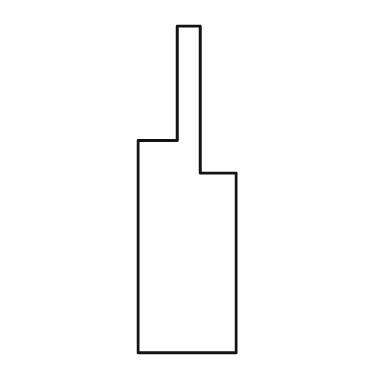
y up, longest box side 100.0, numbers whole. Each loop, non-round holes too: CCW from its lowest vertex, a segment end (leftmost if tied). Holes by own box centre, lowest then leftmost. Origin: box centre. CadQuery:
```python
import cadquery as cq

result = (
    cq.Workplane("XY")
    .moveTo(-15.0, -50.0)
    .lineTo(15.0, -50.0)
    .lineTo(15.0, 5.0)
    .lineTo(4.0, 5.0)
    .lineTo(4.0, 50.0)
    .lineTo(-3.0, 50.0)
    .lineTo(-3.0, 15.0)
    .lineTo(-15.0, 15.0)
    .close()
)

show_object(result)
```